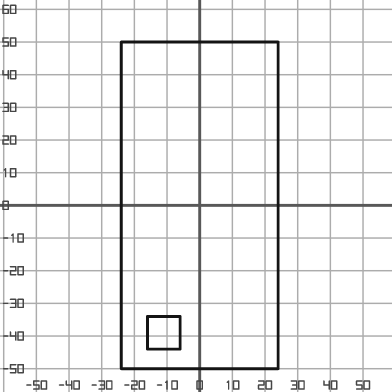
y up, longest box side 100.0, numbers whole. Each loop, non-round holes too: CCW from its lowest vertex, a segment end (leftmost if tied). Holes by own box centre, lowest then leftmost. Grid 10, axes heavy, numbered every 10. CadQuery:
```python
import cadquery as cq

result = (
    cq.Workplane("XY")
    .moveTo(-24.0, -50.0)
    .lineTo(24.0, -50.0)
    .lineTo(24.0, 50.0)
    .lineTo(-24.0, 50.0)
    .close()
    .moveTo(-16.0, -44.0)
    .lineTo(-6.0, -44.0)
    .lineTo(-6.0, -34.0)
    .lineTo(-16.0, -34.0)
    .close()
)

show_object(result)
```